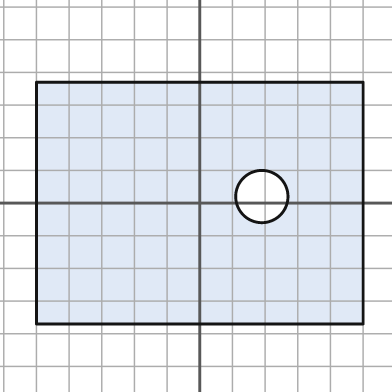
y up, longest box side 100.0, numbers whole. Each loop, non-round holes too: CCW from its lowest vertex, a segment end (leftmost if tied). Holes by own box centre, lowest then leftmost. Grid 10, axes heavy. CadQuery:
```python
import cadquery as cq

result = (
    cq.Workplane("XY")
    .moveTo(-50.0, -37.0)
    .lineTo(50.0, -37.0)
    .lineTo(50.0, 37.0)
    .lineTo(-50.0, 37.0)
    .close()
    .moveTo(19.0, 2.0)
    .circle(8.0)
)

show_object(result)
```